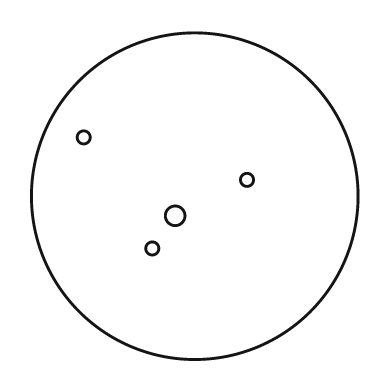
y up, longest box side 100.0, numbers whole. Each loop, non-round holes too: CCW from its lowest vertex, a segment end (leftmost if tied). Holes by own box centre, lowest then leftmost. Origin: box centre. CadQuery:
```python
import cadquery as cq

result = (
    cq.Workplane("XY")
    .moveTo(0.0, 0.0)
    .circle(50.0)
    .moveTo(-13.0, -16.0)
    .circle(2.0)
    .moveTo(-6.0, -6.0)
    .circle(3.0)
    .moveTo(16.0, 5.0)
    .circle(2.0)
    .moveTo(-34.0, 18.0)
    .circle(2.0)
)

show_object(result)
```